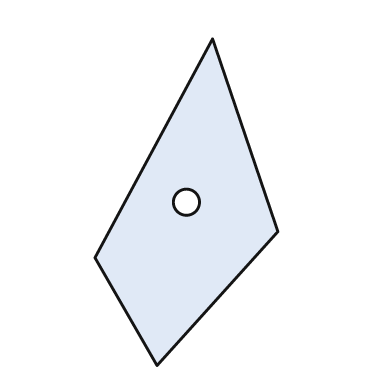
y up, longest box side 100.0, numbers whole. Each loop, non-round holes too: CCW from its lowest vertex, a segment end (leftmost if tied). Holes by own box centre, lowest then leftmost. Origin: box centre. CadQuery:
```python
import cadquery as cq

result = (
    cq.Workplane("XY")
    .moveTo(-9.0, -50.0)
    .lineTo(28.0, -9.0)
    .lineTo(8.0, 50.0)
    .lineTo(-28.0, -17.0)
    .close()
    .moveTo(0.0, 0.0)
    .circle(4.0)
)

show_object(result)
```